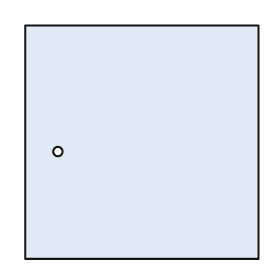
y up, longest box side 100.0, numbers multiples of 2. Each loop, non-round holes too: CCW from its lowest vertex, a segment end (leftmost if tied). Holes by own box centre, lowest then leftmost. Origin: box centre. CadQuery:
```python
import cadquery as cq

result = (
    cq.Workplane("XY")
    .moveTo(-50.0, -50.0)
    .lineTo(50.0, -50.0)
    .lineTo(50.0, 50.0)
    .lineTo(-50.0, 50.0)
    .close()
    .moveTo(-36.0, -4.0)
    .circle(2.0)
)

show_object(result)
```